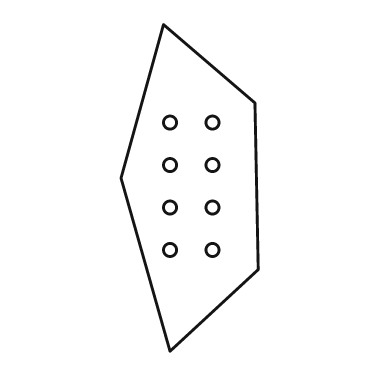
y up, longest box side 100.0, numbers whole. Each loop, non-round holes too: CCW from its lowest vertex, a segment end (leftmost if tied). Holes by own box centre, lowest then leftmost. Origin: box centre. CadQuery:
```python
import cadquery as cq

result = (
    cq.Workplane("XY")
    .moveTo(-6.0, -50.0)
    .lineTo(21.0, -25.0)
    .lineTo(20.0, 26.0)
    .lineTo(-8.0, 50.0)
    .lineTo(-21.0, 3.0)
    .close()
    .moveTo(-6.0, -19.0)
    .circle(2.0)
    .moveTo(7.0, -19.0)
    .circle(2.0)
    .moveTo(-6.0, -6.0)
    .circle(2.0)
    .moveTo(7.0, -6.0)
    .circle(2.0)
    .moveTo(-6.0, 7.0)
    .circle(2.0)
    .moveTo(7.0, 7.0)
    .circle(2.0)
    .moveTo(-6.0, 20.0)
    .circle(2.0)
    .moveTo(7.0, 20.0)
    .circle(2.0)
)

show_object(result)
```